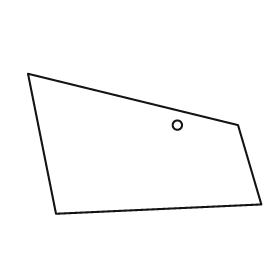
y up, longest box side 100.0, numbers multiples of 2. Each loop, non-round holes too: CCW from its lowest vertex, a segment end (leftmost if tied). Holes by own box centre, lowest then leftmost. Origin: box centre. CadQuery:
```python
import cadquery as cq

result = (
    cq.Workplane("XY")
    .moveTo(-38.0, -30.0)
    .lineTo(50.0, -26.0)
    .lineTo(40.0, 8.0)
    .lineTo(-50.0, 30.0)
    .close()
    .moveTo(14.0, 8.0)
    .circle(2.0)
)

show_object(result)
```